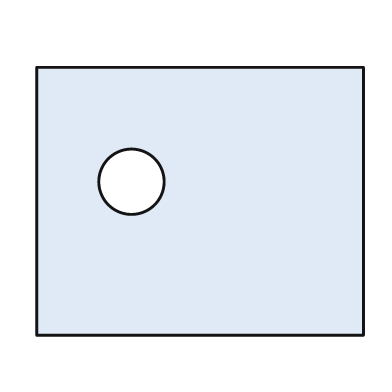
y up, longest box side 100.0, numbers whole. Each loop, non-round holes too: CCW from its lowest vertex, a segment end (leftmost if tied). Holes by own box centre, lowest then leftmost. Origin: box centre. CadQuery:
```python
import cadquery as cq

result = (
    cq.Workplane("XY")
    .moveTo(-50.0, -41.0)
    .lineTo(50.0, -41.0)
    .lineTo(50.0, 41.0)
    .lineTo(-50.0, 41.0)
    .close()
    .moveTo(-21.0, 6.0)
    .circle(10.0)
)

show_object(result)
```